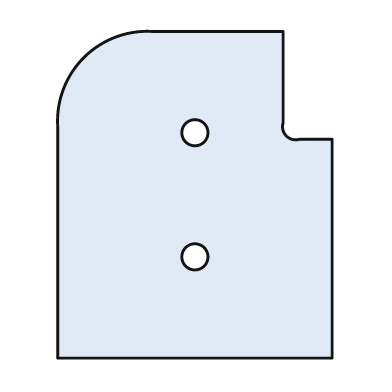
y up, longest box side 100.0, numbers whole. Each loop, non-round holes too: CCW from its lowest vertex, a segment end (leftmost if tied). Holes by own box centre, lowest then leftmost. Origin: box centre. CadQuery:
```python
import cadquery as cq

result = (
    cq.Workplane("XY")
    .moveTo(-42.0, -50.0)
    .lineTo(42.0, -50.0)
    .lineTo(42.0, 17.0)
    .lineTo(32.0, 17.0)
    .threePointArc((28.0, 18.0), (27.0, 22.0))
    .lineTo(27.0, 50.0)
    .lineTo(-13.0, 50.0)
    .threePointArc((-34.0, 42.0), (-42.0, 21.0))
    .close()
    .moveTo(0.0, -19.0)
    .circle(4.0)
    .moveTo(0.0, 19.0)
    .circle(4.0)
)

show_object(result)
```